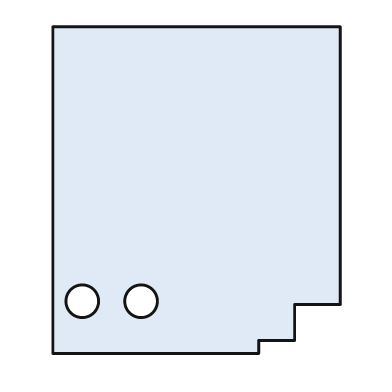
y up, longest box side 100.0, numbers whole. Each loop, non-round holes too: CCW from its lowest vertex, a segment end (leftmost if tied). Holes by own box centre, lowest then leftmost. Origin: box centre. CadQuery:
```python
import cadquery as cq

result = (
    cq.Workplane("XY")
    .moveTo(-44.0, -50.0)
    .lineTo(19.0, -50.0)
    .lineTo(19.0, -46.0)
    .lineTo(30.0, -46.0)
    .lineTo(30.0, -35.0)
    .lineTo(44.0, -35.0)
    .lineTo(44.0, 50.0)
    .lineTo(-44.0, 50.0)
    .close()
    .moveTo(-35.0, -34.0)
    .circle(5.0)
    .moveTo(-17.0, -34.0)
    .circle(5.0)
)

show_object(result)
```